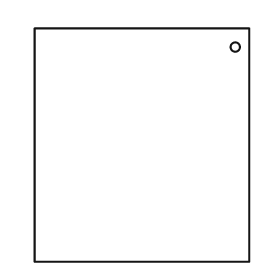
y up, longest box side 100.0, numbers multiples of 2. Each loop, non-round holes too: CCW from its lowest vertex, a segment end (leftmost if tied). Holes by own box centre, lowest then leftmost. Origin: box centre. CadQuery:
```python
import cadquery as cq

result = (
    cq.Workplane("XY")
    .moveTo(-46.0, -50.0)
    .lineTo(46.0, -50.0)
    .lineTo(46.0, 50.0)
    .lineTo(-46.0, 50.0)
    .close()
    .moveTo(40.0, 42.0)
    .circle(2.0)
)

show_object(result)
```